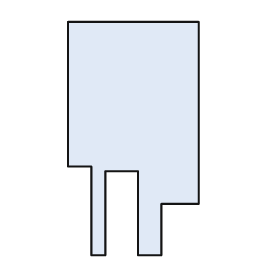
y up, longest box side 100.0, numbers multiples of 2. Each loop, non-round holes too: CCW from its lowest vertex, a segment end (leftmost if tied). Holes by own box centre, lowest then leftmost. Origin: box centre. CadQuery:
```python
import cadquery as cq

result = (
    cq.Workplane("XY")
    .moveTo(-18.0, -50.0)
    .lineTo(-12.0, -50.0)
    .lineTo(-12.0, -14.0)
    .lineTo(2.0, -14.0)
    .lineTo(2.0, -50.0)
    .lineTo(12.0, -50.0)
    .lineTo(12.0, -28.0)
    .lineTo(28.0, -28.0)
    .lineTo(28.0, 50.0)
    .lineTo(-28.0, 50.0)
    .lineTo(-28.0, -12.0)
    .lineTo(-18.0, -12.0)
    .close()
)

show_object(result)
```